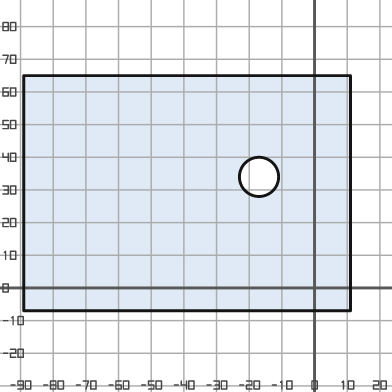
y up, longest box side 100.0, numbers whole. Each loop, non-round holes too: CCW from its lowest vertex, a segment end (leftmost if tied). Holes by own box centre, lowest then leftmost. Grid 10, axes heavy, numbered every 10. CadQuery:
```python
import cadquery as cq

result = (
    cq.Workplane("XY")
    .moveTo(-89.0, -7.0)
    .lineTo(11.0, -7.0)
    .lineTo(11.0, 65.0)
    .lineTo(-89.0, 65.0)
    .close()
    .moveTo(-17.0, 34.0)
    .circle(6.0)
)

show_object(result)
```